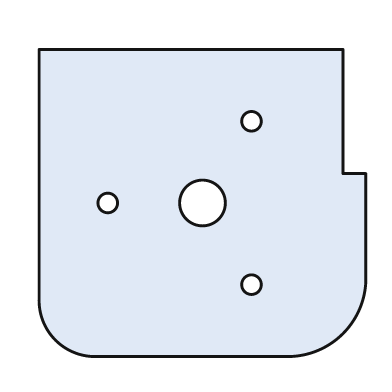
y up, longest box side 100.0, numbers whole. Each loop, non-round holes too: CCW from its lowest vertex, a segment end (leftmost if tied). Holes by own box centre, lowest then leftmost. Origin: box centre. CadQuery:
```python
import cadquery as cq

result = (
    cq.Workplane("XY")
    .moveTo(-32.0, -47.0)
    .lineTo(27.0, -47.0)
    .threePointArc((43.0, -40.0), (50.0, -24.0))
    .lineTo(50.0, 9.0)
    .lineTo(43.0, 9.0)
    .lineTo(43.0, 47.0)
    .lineTo(-50.0, 47.0)
    .lineTo(-50.0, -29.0)
    .threePointArc((-45.0, -42.0), (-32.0, -47.0))
    .close()
    .moveTo(15.0, -25.0)
    .circle(3.0)
    .moveTo(-29.0, 0.0)
    .circle(3.0)
    .moveTo(0.0, 0.0)
    .circle(7.0)
    .moveTo(15.0, 25.0)
    .circle(3.0)
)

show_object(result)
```